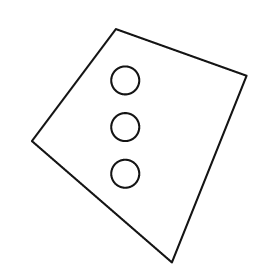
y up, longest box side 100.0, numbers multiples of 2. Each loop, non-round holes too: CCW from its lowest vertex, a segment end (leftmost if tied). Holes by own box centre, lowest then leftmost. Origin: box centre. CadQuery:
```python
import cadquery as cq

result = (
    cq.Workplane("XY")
    .moveTo(14.0, -50.0)
    .lineTo(46.0, 30.0)
    .lineTo(-10.0, 50.0)
    .lineTo(-46.0, 2.0)
    .close()
    .moveTo(-6.0, -12.0)
    .circle(6.0)
    .moveTo(-6.0, 8.0)
    .circle(6.0)
    .moveTo(-6.0, 28.0)
    .circle(6.0)
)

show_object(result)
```